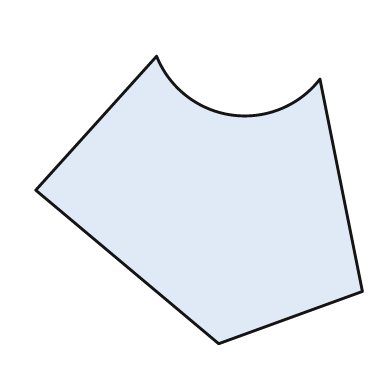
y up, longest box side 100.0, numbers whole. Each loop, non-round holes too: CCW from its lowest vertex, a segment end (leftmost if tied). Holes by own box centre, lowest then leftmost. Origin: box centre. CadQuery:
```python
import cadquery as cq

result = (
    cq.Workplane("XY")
    .moveTo(6.0, -44.0)
    .lineTo(50.0, -28.0)
    .lineTo(37.0, 37.0)
    .threePointArc((10.0, 26.0), (-13.0, 44.0))
    .lineTo(-50.0, 3.0)
    .close()
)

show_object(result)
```